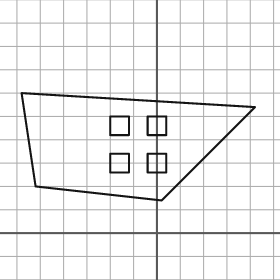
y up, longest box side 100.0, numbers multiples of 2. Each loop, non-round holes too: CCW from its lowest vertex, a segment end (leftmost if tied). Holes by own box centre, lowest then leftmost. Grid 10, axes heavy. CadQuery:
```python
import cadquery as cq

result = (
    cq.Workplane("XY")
    .moveTo(2.0, 14.0)
    .lineTo(42.0, 54.0)
    .lineTo(-58.0, 60.0)
    .lineTo(-52.0, 20.0)
    .close()
    .moveTo(-20.0, 26.0)
    .lineTo(-12.0, 26.0)
    .lineTo(-12.0, 34.0)
    .lineTo(-20.0, 34.0)
    .close()
    .moveTo(-4.0, 26.0)
    .lineTo(4.0, 26.0)
    .lineTo(4.0, 34.0)
    .lineTo(-4.0, 34.0)
    .close()
    .moveTo(-20.0, 42.0)
    .lineTo(-12.0, 42.0)
    .lineTo(-12.0, 50.0)
    .lineTo(-20.0, 50.0)
    .close()
    .moveTo(-4.0, 42.0)
    .lineTo(4.0, 42.0)
    .lineTo(4.0, 50.0)
    .lineTo(-4.0, 50.0)
    .close()
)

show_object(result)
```